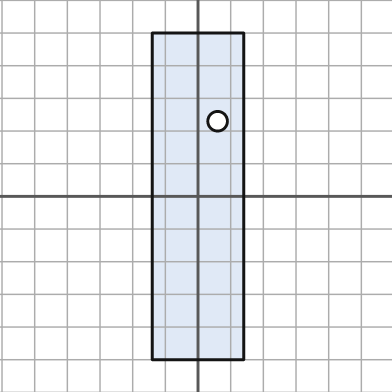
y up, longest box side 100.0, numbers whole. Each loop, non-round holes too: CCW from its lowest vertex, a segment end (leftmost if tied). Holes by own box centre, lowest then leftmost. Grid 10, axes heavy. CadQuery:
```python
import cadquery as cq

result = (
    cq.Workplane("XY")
    .moveTo(-14.0, -50.0)
    .lineTo(14.0, -50.0)
    .lineTo(14.0, 50.0)
    .lineTo(-14.0, 50.0)
    .close()
    .moveTo(6.0, 23.0)
    .circle(3.0)
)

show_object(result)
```